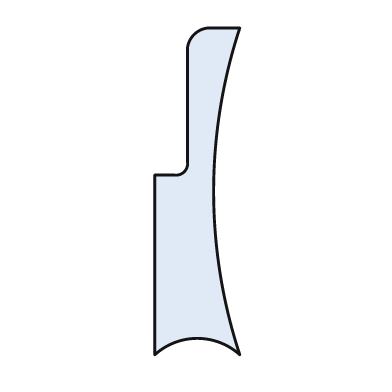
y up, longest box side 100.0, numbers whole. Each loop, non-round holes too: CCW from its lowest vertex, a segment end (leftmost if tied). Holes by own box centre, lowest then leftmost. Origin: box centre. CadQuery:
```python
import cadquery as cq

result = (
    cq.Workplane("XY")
    .moveTo(-13.0, -50.0)
    .threePointArc((0.0, -45.0), (13.0, -50.0))
    .threePointArc((5.0, 0.0), (13.0, 50.0))
    .lineTo(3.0, 50.0)
    .threePointArc((-1.0, 48.0), (-3.0, 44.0))
    .lineTo(-3.0, 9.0)
    .threePointArc((-4.0, 6.0), (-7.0, 5.0))
    .lineTo(-13.0, 5.0)
    .close()
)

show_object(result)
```